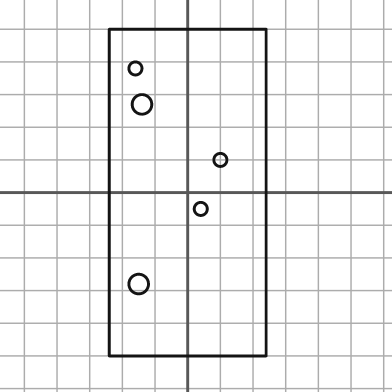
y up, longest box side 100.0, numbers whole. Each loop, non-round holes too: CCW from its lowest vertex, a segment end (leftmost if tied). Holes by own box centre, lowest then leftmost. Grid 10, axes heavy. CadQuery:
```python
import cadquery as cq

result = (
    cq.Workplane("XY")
    .moveTo(-24.0, -50.0)
    .lineTo(24.0, -50.0)
    .lineTo(24.0, 50.0)
    .lineTo(-24.0, 50.0)
    .close()
    .moveTo(-15.0, -28.0)
    .circle(3.0)
    .moveTo(4.0, -5.0)
    .circle(2.0)
    .moveTo(10.0, 10.0)
    .circle(2.0)
    .moveTo(-14.0, 27.0)
    .circle(3.0)
    .moveTo(-16.0, 38.0)
    .circle(2.0)
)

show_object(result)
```